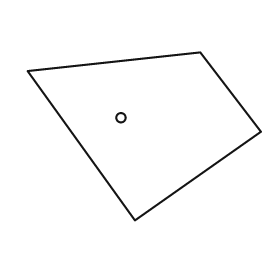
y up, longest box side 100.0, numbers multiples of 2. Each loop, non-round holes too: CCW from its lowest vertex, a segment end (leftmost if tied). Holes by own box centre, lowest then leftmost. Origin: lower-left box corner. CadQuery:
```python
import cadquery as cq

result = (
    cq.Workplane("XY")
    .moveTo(46.0, 0.0)
    .lineTo(100.0, 38.0)
    .lineTo(74.0, 72.0)
    .lineTo(0.0, 64.0)
    .close()
    .moveTo(40.0, 44.0)
    .circle(2.0)
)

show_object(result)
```